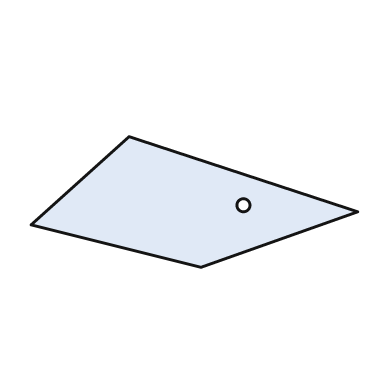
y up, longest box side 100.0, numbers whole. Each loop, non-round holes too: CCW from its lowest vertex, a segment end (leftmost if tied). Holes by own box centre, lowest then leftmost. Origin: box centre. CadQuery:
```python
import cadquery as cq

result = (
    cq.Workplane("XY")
    .moveTo(2.0, -20.0)
    .lineTo(50.0, -3.0)
    .lineTo(-20.0, 20.0)
    .lineTo(-50.0, -7.0)
    .close()
    .moveTo(15.0, -1.0)
    .circle(2.0)
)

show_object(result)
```